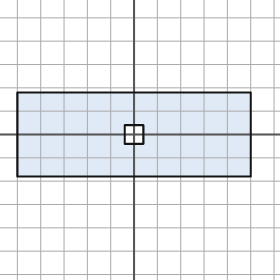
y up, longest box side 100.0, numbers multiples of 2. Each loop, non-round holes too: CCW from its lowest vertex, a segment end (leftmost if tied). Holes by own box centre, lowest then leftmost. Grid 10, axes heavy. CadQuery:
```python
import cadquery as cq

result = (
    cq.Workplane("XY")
    .moveTo(-50.0, -18.0)
    .lineTo(50.0, -18.0)
    .lineTo(50.0, 18.0)
    .lineTo(-50.0, 18.0)
    .close()
    .moveTo(-4.0, -4.0)
    .lineTo(4.0, -4.0)
    .lineTo(4.0, 4.0)
    .lineTo(-4.0, 4.0)
    .close()
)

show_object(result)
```